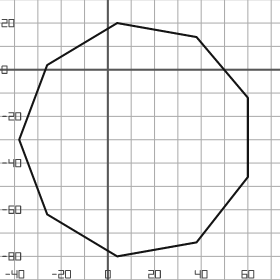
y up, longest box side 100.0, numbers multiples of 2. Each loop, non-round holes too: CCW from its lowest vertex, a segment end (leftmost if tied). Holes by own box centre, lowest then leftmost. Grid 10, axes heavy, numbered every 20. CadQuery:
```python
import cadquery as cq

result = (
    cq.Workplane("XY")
    .moveTo(4.0, -80.0)
    .lineTo(38.0, -74.0)
    .lineTo(60.0, -46.0)
    .lineTo(60.0, -12.0)
    .lineTo(38.0, 14.0)
    .lineTo(4.0, 20.0)
    .lineTo(-26.0, 2.0)
    .lineTo(-38.0, -30.0)
    .lineTo(-26.0, -62.0)
    .close()
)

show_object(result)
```